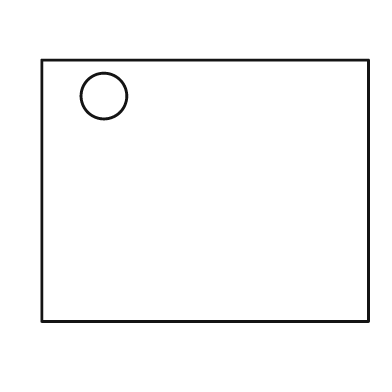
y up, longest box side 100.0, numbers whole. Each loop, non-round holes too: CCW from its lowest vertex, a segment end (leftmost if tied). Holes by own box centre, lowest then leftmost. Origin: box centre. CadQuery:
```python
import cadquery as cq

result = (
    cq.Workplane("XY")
    .moveTo(-50.0, -40.0)
    .lineTo(50.0, -40.0)
    .lineTo(50.0, 40.0)
    .lineTo(-50.0, 40.0)
    .close()
    .moveTo(-31.0, 29.0)
    .circle(7.0)
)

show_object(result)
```